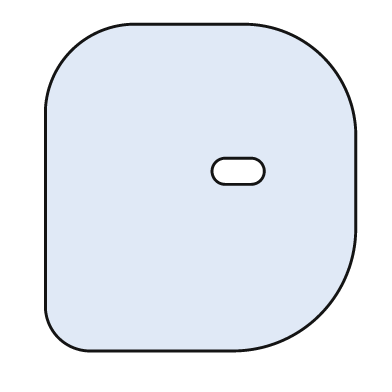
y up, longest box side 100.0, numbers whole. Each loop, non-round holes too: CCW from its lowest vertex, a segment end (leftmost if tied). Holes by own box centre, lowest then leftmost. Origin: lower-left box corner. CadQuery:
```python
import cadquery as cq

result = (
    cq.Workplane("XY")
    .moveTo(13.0, 0.0)
    .lineTo(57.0, 0.0)
    .threePointArc((84.0, 11.0), (95.0, 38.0))
    .lineTo(95.0, 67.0)
    .threePointArc((85.0, 90.0), (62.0, 100.0))
    .lineTo(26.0, 100.0)
    .threePointArc((8.0, 92.0), (0.0, 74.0))
    .lineTo(0.0, 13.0)
    .threePointArc((4.0, 4.0), (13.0, 0.0))
    .close()
    .moveTo(55.0, 51.0)
    .lineTo(63.0, 51.0)
    .threePointArc((67.0, 55.0), (63.0, 59.0))
    .lineTo(55.0, 59.0)
    .threePointArc((51.0, 55.0), (55.0, 51.0))
    .close()
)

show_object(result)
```